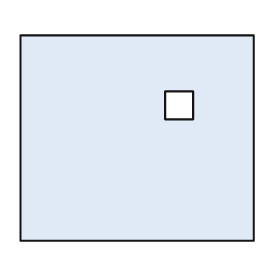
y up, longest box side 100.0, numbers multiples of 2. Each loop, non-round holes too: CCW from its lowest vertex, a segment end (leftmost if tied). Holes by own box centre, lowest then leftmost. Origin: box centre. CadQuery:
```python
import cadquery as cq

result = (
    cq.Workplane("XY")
    .moveTo(-50.0, -44.0)
    .lineTo(50.0, -44.0)
    .lineTo(50.0, 44.0)
    .lineTo(-50.0, 44.0)
    .close()
    .moveTo(12.0, 8.0)
    .lineTo(24.0, 8.0)
    .lineTo(24.0, 20.0)
    .lineTo(12.0, 20.0)
    .close()
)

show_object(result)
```